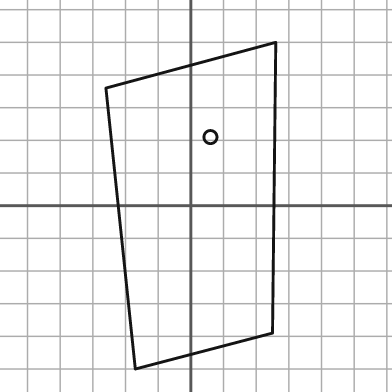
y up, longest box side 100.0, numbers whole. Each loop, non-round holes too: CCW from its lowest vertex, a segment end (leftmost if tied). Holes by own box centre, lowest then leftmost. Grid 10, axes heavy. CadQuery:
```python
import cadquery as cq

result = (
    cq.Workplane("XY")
    .moveTo(-17.0, -50.0)
    .lineTo(25.0, -39.0)
    .lineTo(26.0, 50.0)
    .lineTo(-26.0, 36.0)
    .close()
    .moveTo(6.0, 21.0)
    .circle(2.0)
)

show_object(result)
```